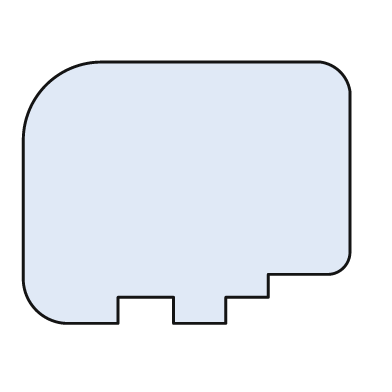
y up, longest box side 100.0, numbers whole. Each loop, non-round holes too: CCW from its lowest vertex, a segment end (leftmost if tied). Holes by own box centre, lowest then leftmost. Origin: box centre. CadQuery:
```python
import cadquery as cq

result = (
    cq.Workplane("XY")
    .moveTo(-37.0, -40.0)
    .lineTo(-21.0, -40.0)
    .lineTo(-21.0, -32.0)
    .lineTo(-4.0, -32.0)
    .lineTo(-4.0, -40.0)
    .lineTo(12.0, -40.0)
    .lineTo(12.0, -32.0)
    .lineTo(25.0, -32.0)
    .lineTo(25.0, -25.0)
    .lineTo(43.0, -25.0)
    .threePointArc((48.0, -23.0), (50.0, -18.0))
    .lineTo(50.0, 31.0)
    .threePointArc((47.0, 37.0), (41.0, 40.0))
    .lineTo(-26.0, 40.0)
    .threePointArc((-43.0, 33.0), (-50.0, 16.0))
    .lineTo(-50.0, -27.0)
    .threePointArc((-46.0, -36.0), (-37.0, -40.0))
    .close()
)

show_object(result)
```